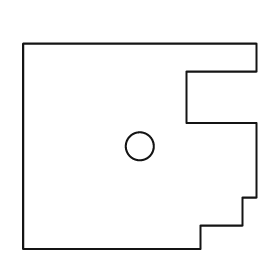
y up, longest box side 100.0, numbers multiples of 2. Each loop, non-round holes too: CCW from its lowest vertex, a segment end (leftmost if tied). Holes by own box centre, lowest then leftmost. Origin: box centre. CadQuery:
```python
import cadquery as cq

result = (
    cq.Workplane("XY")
    .moveTo(-50.0, -44.0)
    .lineTo(26.0, -44.0)
    .lineTo(26.0, -34.0)
    .lineTo(44.0, -34.0)
    .lineTo(44.0, -22.0)
    .lineTo(50.0, -22.0)
    .lineTo(50.0, 10.0)
    .lineTo(20.0, 10.0)
    .lineTo(20.0, 32.0)
    .lineTo(50.0, 32.0)
    .lineTo(50.0, 44.0)
    .lineTo(-50.0, 44.0)
    .close()
    .moveTo(0.0, 0.0)
    .circle(6.0)
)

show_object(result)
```